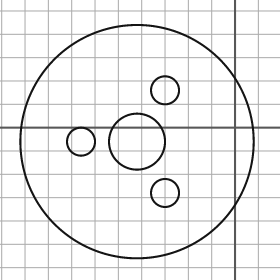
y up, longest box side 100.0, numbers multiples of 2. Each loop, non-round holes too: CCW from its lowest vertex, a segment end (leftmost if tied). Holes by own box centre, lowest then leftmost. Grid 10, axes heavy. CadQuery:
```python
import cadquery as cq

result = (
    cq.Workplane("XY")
    .moveTo(-42.0, -6.0)
    .circle(50.0)
    .moveTo(-30.0, -28.0)
    .circle(6.0)
    .moveTo(-66.0, -6.0)
    .circle(6.0)
    .moveTo(-42.0, -6.0)
    .circle(12.0)
    .moveTo(-30.0, 16.0)
    .circle(6.0)
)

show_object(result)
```